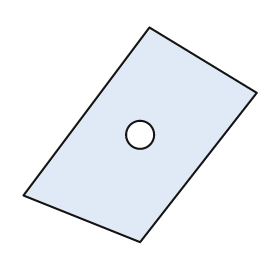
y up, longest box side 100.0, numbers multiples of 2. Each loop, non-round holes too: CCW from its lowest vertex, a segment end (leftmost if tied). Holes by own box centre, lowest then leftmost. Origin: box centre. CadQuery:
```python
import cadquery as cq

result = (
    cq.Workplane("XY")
    .moveTo(0.0, -46.0)
    .lineTo(50.0, 18.0)
    .lineTo(4.0, 46.0)
    .lineTo(-50.0, -26.0)
    .close()
    .moveTo(0.0, 0.0)
    .circle(6.0)
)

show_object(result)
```